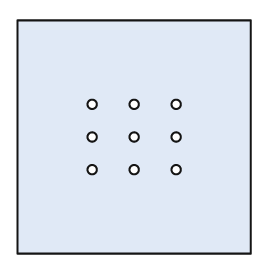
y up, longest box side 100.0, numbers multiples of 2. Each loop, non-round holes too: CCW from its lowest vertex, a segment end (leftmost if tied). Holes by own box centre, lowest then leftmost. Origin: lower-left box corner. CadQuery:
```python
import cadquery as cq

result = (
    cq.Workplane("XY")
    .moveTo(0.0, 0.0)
    .lineTo(100.0, 0.0)
    .lineTo(100.0, 100.0)
    .lineTo(0.0, 100.0)
    .close()
    .moveTo(32.0, 36.0)
    .circle(2.0)
    .moveTo(50.0, 36.0)
    .circle(2.0)
    .moveTo(68.0, 36.0)
    .circle(2.0)
    .moveTo(32.0, 50.0)
    .circle(2.0)
    .moveTo(50.0, 50.0)
    .circle(2.0)
    .moveTo(68.0, 50.0)
    .circle(2.0)
    .moveTo(32.0, 64.0)
    .circle(2.0)
    .moveTo(50.0, 64.0)
    .circle(2.0)
    .moveTo(68.0, 64.0)
    .circle(2.0)
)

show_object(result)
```